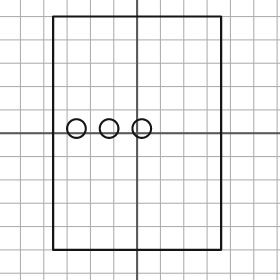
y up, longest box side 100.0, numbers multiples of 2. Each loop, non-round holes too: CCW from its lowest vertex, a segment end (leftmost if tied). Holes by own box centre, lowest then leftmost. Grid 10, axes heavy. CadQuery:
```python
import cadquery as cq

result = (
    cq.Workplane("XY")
    .moveTo(-36.0, -50.0)
    .lineTo(36.0, -50.0)
    .lineTo(36.0, 50.0)
    .lineTo(-36.0, 50.0)
    .close()
    .moveTo(-26.0, 2.0)
    .circle(4.0)
    .moveTo(-12.0, 2.0)
    .circle(4.0)
    .moveTo(2.0, 2.0)
    .circle(4.0)
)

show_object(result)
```